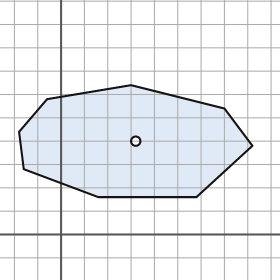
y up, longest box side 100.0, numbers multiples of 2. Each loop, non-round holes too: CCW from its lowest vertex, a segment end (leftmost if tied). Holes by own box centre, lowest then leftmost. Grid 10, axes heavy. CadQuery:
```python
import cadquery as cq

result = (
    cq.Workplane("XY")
    .moveTo(16.0, 16.0)
    .lineTo(58.0, 16.0)
    .lineTo(82.0, 38.0)
    .lineTo(70.0, 54.0)
    .lineTo(30.0, 64.0)
    .lineTo(-6.0, 58.0)
    .lineTo(-18.0, 44.0)
    .lineTo(-16.0, 28.0)
    .close()
    .moveTo(32.0, 40.0)
    .circle(2.0)
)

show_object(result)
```